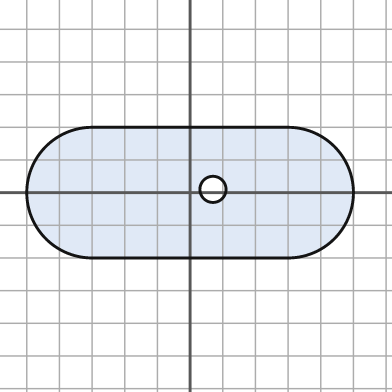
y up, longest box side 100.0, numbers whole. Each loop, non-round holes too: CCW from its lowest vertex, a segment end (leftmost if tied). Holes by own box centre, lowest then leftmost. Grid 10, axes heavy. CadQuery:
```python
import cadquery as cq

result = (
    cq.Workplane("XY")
    .moveTo(-30.0, -20.0)
    .lineTo(30.0, -20.0)
    .threePointArc((50.0, 0.0), (30.0, 20.0))
    .lineTo(-30.0, 20.0)
    .threePointArc((-50.0, 0.0), (-30.0, -20.0))
    .close()
    .moveTo(7.0, 1.0)
    .circle(4.0)
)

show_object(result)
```